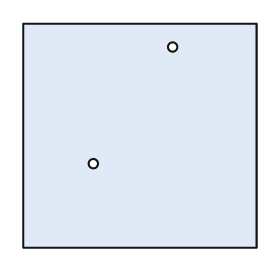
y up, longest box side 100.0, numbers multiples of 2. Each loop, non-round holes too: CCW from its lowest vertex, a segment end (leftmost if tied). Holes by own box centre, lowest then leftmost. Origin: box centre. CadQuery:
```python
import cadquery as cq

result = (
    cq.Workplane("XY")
    .moveTo(-50.0, -48.0)
    .lineTo(50.0, -48.0)
    .lineTo(50.0, 48.0)
    .lineTo(-50.0, 48.0)
    .close()
    .moveTo(-20.0, -12.0)
    .circle(2.0)
    .moveTo(14.0, 38.0)
    .circle(2.0)
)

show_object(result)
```